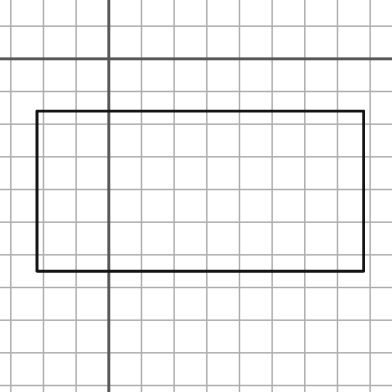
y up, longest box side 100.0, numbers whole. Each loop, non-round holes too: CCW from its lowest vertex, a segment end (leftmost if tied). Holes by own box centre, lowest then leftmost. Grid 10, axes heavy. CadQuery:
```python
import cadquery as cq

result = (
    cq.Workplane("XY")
    .moveTo(-22.0, -65.0)
    .lineTo(78.0, -65.0)
    .lineTo(78.0, -16.0)
    .lineTo(-22.0, -16.0)
    .close()
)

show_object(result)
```